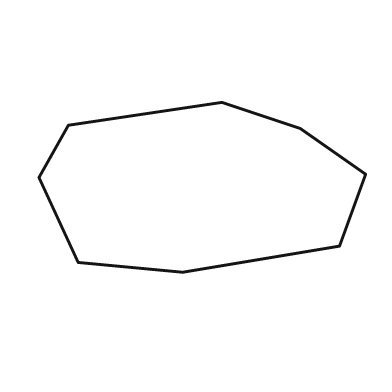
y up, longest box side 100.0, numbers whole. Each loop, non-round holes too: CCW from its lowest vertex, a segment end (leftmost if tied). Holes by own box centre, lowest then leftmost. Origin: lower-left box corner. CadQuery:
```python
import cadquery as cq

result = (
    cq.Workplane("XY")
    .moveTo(44.0, 0.0)
    .lineTo(92.0, 8.0)
    .lineTo(100.0, 30.0)
    .lineTo(80.0, 44.0)
    .lineTo(56.0, 52.0)
    .lineTo(9.0, 45.0)
    .lineTo(0.0, 29.0)
    .lineTo(12.0, 3.0)
    .close()
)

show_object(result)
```